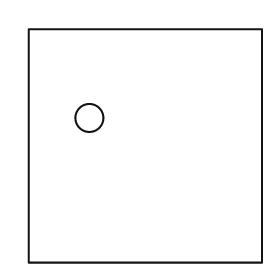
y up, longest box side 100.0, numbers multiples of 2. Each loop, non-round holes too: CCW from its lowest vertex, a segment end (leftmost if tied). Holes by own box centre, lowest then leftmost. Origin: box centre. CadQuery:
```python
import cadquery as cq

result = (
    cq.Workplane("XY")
    .moveTo(-50.0, -50.0)
    .lineTo(50.0, -50.0)
    .lineTo(50.0, 50.0)
    .lineTo(-50.0, 50.0)
    .close()
    .moveTo(-24.0, 12.0)
    .circle(6.0)
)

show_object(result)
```